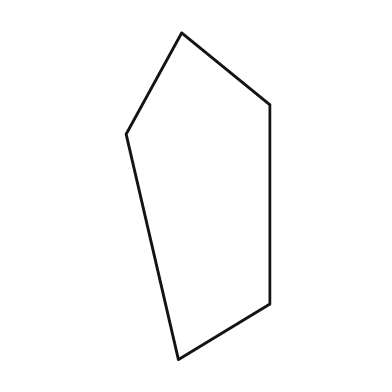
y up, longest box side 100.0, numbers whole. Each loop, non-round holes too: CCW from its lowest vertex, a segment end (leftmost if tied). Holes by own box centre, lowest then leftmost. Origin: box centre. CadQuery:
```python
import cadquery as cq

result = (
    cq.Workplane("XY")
    .moveTo(-6.0, -50.0)
    .lineTo(22.0, -33.0)
    .lineTo(22.0, 28.0)
    .lineTo(-5.0, 50.0)
    .lineTo(-22.0, 19.0)
    .close()
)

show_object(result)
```